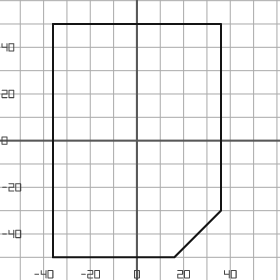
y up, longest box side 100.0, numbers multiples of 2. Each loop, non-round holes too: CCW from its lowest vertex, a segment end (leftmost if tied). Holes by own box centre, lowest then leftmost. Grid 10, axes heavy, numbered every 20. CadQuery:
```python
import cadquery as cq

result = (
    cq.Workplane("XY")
    .moveTo(-36.0, -50.0)
    .lineTo(16.0, -50.0)
    .lineTo(36.0, -30.0)
    .lineTo(36.0, 50.0)
    .lineTo(-36.0, 50.0)
    .close()
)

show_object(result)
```